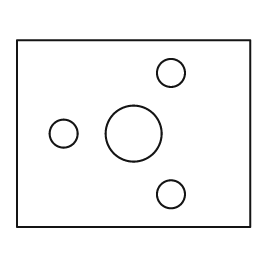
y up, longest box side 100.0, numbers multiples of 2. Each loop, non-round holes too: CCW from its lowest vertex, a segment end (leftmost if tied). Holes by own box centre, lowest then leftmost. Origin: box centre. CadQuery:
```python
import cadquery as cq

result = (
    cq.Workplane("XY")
    .moveTo(-50.0, -40.0)
    .lineTo(50.0, -40.0)
    .lineTo(50.0, 40.0)
    .lineTo(-50.0, 40.0)
    .close()
    .moveTo(16.0, -26.0)
    .circle(6.0)
    .moveTo(-30.0, 0.0)
    .circle(6.0)
    .moveTo(0.0, 0.0)
    .circle(12.0)
    .moveTo(16.0, 26.0)
    .circle(6.0)
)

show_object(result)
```